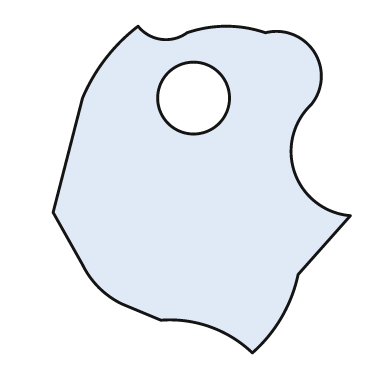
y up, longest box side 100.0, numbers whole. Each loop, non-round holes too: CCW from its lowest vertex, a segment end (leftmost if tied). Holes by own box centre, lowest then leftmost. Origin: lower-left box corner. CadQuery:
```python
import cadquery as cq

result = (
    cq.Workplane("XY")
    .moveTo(61.0, 0.0)
    .threePointArc((70.0, 11.0), (75.0, 24.0))
    .lineTo(91.0, 42.0)
    .threePointArc((74.0, 55.0), (79.0, 76.0))
    .threePointArc((80.0, 92.0), (65.0, 98.0))
    .threePointArc((53.0, 100.0), (41.0, 98.0))
    .threePointArc((33.0, 96.0), (26.0, 100.0))
    .threePointArc((16.0, 90.0), (9.0, 78.0))
    .lineTo(0.0, 43.0)
    .lineTo(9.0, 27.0)
    .threePointArc((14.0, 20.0), (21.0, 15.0))
    .lineTo(33.0, 10.0)
    .threePointArc((48.0, 8.0), (61.0, 0.0))
    .close()
    .moveTo(43.0, 78.0)
    .circle(11.0)
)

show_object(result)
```